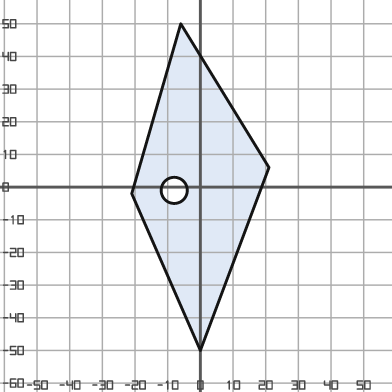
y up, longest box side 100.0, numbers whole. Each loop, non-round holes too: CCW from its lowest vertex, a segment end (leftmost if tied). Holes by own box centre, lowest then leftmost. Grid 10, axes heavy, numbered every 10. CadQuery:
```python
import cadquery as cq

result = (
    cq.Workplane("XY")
    .moveTo(0.0, -50.0)
    .lineTo(21.0, 6.0)
    .lineTo(-6.0, 50.0)
    .lineTo(-21.0, -2.0)
    .close()
    .moveTo(-8.0, -1.0)
    .circle(4.0)
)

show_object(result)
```